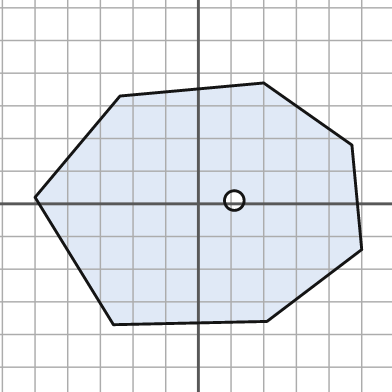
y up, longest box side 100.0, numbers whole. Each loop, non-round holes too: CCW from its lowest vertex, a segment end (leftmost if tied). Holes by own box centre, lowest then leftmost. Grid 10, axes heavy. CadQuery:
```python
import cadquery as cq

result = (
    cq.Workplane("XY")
    .moveTo(-26.0, -37.0)
    .lineTo(21.0, -36.0)
    .lineTo(50.0, -14.0)
    .lineTo(47.0, 18.0)
    .lineTo(20.0, 37.0)
    .lineTo(-24.0, 33.0)
    .lineTo(-50.0, 2.0)
    .close()
    .moveTo(11.0, 1.0)
    .circle(3.0)
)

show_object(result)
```